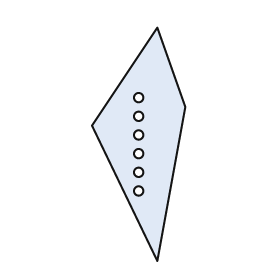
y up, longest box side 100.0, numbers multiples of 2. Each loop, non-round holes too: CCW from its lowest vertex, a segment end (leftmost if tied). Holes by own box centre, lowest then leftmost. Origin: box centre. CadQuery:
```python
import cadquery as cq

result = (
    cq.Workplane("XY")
    .moveTo(8.0, -50.0)
    .lineTo(20.0, 16.0)
    .lineTo(8.0, 50.0)
    .lineTo(-20.0, 8.0)
    .close()
    .moveTo(0.0, -20.0)
    .circle(2.0)
    .moveTo(0.0, -12.0)
    .circle(2.0)
    .moveTo(0.0, -4.0)
    .circle(2.0)
    .moveTo(0.0, 4.0)
    .circle(2.0)
    .moveTo(0.0, 12.0)
    .circle(2.0)
    .moveTo(0.0, 20.0)
    .circle(2.0)
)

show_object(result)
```